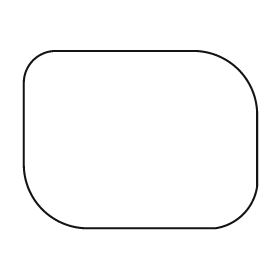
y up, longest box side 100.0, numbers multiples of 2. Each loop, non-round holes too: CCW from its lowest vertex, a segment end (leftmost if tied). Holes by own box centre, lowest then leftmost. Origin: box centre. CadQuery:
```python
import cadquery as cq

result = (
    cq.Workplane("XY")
    .moveTo(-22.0, -38.0)
    .lineTo(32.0, -38.0)
    .threePointArc((44.0, -32.0), (50.0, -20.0))
    .lineTo(50.0, 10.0)
    .threePointArc((42.0, 30.0), (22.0, 38.0))
    .lineTo(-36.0, 38.0)
    .threePointArc((-46.0, 34.0), (-50.0, 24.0))
    .lineTo(-50.0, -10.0)
    .threePointArc((-42.0, -30.0), (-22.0, -38.0))
    .close()
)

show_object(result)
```